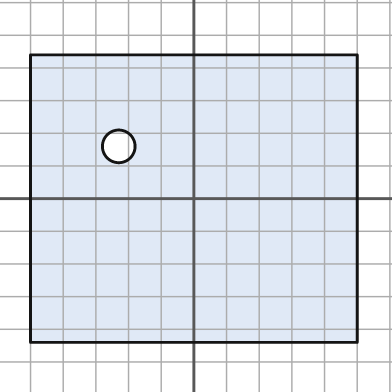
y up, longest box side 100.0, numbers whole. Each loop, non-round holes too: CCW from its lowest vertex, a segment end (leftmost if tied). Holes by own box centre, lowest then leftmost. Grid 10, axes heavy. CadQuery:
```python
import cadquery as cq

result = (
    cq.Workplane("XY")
    .moveTo(-50.0, -44.0)
    .lineTo(50.0, -44.0)
    .lineTo(50.0, 44.0)
    .lineTo(-50.0, 44.0)
    .close()
    .moveTo(-23.0, 16.0)
    .circle(5.0)
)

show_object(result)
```